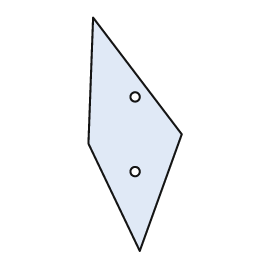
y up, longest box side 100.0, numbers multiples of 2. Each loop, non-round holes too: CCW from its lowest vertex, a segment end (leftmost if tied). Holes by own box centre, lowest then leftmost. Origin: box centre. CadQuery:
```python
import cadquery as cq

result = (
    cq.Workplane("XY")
    .moveTo(2.0, -50.0)
    .lineTo(20.0, 0.0)
    .lineTo(-18.0, 50.0)
    .lineTo(-20.0, -4.0)
    .close()
    .moveTo(0.0, -16.0)
    .circle(2.0)
    .moveTo(0.0, 16.0)
    .circle(2.0)
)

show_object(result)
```